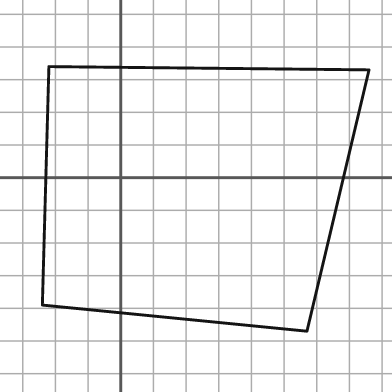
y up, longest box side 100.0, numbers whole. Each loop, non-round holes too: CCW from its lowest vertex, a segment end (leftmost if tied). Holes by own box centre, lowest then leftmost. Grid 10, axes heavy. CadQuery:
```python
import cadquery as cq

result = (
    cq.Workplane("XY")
    .moveTo(57.0, -47.0)
    .lineTo(76.0, 33.0)
    .lineTo(-22.0, 34.0)
    .lineTo(-24.0, -39.0)
    .close()
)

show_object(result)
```